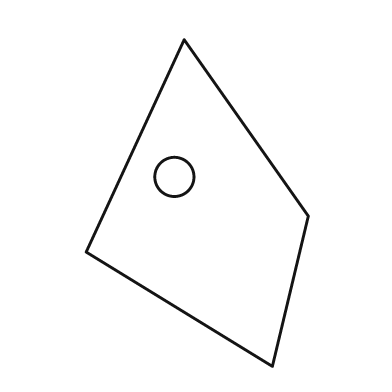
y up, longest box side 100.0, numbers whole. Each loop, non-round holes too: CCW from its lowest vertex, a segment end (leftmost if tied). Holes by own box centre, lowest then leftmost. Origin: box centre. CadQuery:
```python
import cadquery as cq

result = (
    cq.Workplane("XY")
    .moveTo(23.0, -50.0)
    .lineTo(34.0, -4.0)
    .lineTo(-4.0, 50.0)
    .lineTo(-34.0, -15.0)
    .close()
    .moveTo(-7.0, 8.0)
    .circle(6.0)
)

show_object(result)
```